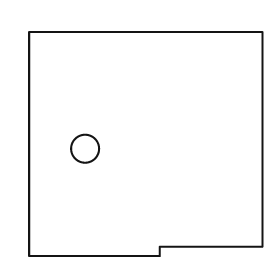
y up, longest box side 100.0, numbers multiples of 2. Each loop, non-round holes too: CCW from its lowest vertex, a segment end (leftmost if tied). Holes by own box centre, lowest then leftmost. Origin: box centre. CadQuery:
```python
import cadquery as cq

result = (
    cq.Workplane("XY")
    .moveTo(-50.0, -48.0)
    .lineTo(6.0, -48.0)
    .lineTo(6.0, -44.0)
    .lineTo(50.0, -44.0)
    .lineTo(50.0, 48.0)
    .lineTo(-50.0, 48.0)
    .close()
    .moveTo(-26.0, -2.0)
    .circle(6.0)
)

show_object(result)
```